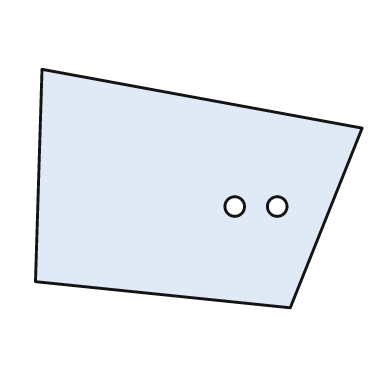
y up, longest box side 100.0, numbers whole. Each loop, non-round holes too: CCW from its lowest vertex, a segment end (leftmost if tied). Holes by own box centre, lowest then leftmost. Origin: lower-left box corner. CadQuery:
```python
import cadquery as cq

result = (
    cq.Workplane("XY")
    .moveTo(78.0, 0.0)
    .lineTo(100.0, 55.0)
    .lineTo(2.0, 73.0)
    .lineTo(0.0, 8.0)
    .close()
    .moveTo(61.0, 31.0)
    .circle(3.0)
    .moveTo(74.0, 31.0)
    .circle(3.0)
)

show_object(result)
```